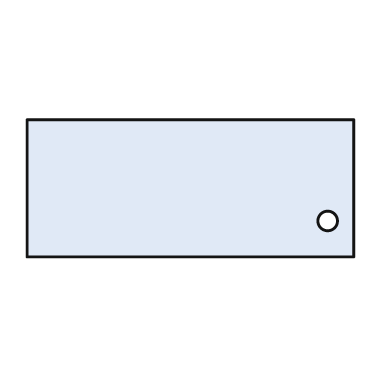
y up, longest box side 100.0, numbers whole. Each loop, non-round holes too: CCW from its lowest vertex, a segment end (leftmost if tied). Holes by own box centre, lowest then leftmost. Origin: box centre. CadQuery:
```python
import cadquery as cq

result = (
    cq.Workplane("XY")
    .moveTo(-50.0, -21.0)
    .lineTo(50.0, -21.0)
    .lineTo(50.0, 21.0)
    .lineTo(-50.0, 21.0)
    .close()
    .moveTo(42.0, -10.0)
    .circle(3.0)
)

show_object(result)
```